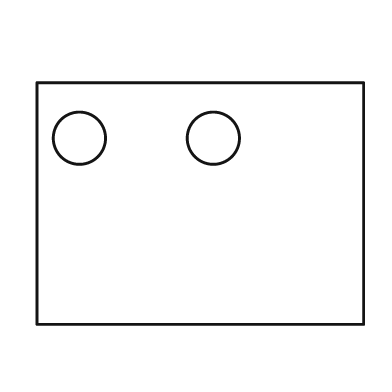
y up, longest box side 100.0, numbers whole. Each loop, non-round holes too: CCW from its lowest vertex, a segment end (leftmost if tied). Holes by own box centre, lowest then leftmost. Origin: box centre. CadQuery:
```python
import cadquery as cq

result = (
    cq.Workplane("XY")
    .moveTo(-50.0, -37.0)
    .lineTo(50.0, -37.0)
    .lineTo(50.0, 37.0)
    .lineTo(-50.0, 37.0)
    .close()
    .moveTo(-37.0, 20.0)
    .circle(8.0)
    .moveTo(4.0, 20.0)
    .circle(8.0)
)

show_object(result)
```